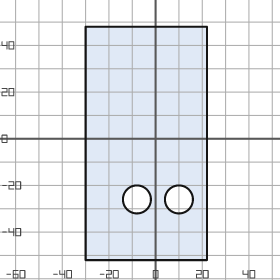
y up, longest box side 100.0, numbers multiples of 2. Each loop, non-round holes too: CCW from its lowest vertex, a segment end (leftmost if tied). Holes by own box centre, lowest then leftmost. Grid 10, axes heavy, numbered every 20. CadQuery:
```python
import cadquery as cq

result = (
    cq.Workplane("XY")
    .moveTo(-30.0, -52.0)
    .lineTo(22.0, -52.0)
    .lineTo(22.0, 48.0)
    .lineTo(-30.0, 48.0)
    .close()
    .moveTo(-8.0, -26.0)
    .circle(6.0)
    .moveTo(10.0, -26.0)
    .circle(6.0)
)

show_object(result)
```